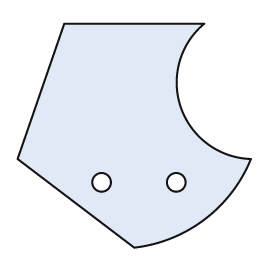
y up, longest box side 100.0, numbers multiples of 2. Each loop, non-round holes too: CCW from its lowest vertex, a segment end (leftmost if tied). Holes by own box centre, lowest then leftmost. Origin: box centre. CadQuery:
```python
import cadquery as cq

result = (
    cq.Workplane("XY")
    .moveTo(0.0, -48.0)
    .threePointArc((30.0, -36.0), (50.0, -10.0))
    .threePointArc((20.0, 12.0), (30.0, 48.0))
    .lineTo(-30.0, 48.0)
    .lineTo(-50.0, -10.0)
    .close()
    .moveTo(-14.0, -20.0)
    .circle(4.0)
    .moveTo(18.0, -20.0)
    .circle(4.0)
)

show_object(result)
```